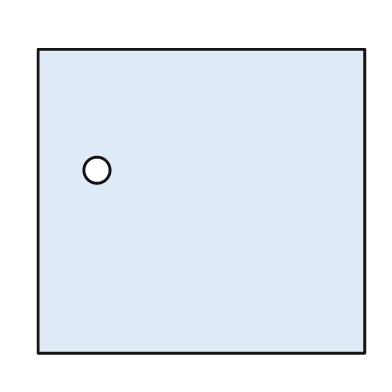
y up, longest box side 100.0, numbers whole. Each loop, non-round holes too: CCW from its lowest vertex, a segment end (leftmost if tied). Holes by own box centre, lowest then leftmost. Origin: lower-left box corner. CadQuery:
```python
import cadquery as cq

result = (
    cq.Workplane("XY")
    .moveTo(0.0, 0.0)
    .lineTo(100.0, 0.0)
    .lineTo(100.0, 93.0)
    .lineTo(0.0, 93.0)
    .close()
    .moveTo(18.0, 56.0)
    .circle(4.0)
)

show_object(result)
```